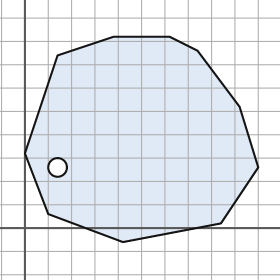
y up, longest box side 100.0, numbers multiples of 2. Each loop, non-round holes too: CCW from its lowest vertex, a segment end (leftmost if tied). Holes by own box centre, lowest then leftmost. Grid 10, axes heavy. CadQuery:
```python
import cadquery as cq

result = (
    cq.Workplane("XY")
    .moveTo(42.0, -6.0)
    .lineTo(84.0, 2.0)
    .lineTo(100.0, 26.0)
    .lineTo(92.0, 52.0)
    .lineTo(74.0, 76.0)
    .lineTo(62.0, 82.0)
    .lineTo(38.0, 82.0)
    .lineTo(14.0, 74.0)
    .lineTo(0.0, 32.0)
    .lineTo(10.0, 6.0)
    .close()
    .moveTo(14.0, 26.0)
    .circle(4.0)
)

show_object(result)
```